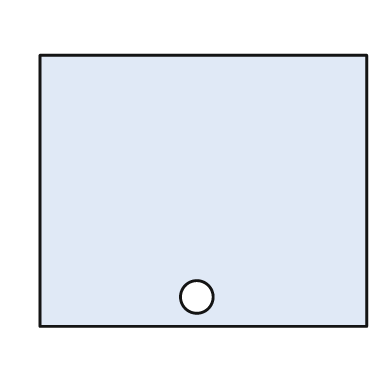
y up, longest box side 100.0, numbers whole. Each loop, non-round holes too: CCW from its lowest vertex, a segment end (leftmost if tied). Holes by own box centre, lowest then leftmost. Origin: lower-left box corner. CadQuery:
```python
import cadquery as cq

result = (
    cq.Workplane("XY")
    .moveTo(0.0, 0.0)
    .lineTo(100.0, 0.0)
    .lineTo(100.0, 83.0)
    .lineTo(0.0, 83.0)
    .close()
    .moveTo(48.0, 9.0)
    .circle(5.0)
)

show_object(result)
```